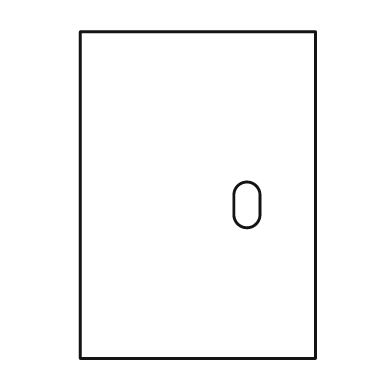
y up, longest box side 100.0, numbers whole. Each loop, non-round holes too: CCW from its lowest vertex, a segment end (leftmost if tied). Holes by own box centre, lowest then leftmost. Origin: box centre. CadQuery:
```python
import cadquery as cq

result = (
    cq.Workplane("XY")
    .moveTo(-36.0, -50.0)
    .lineTo(36.0, -50.0)
    .lineTo(36.0, 50.0)
    .lineTo(-36.0, 50.0)
    .close()
    .moveTo(11.0, -6.0)
    .threePointArc((15.0, -10.0), (19.0, -6.0))
    .lineTo(19.0, 0.0)
    .threePointArc((15.0, 4.0), (11.0, 0.0))
    .close()
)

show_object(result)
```